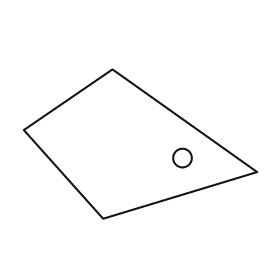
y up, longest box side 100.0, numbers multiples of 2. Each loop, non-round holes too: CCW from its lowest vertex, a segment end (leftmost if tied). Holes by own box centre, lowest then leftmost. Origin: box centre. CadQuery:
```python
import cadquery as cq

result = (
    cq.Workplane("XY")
    .moveTo(-16.0, -32.0)
    .lineTo(50.0, -12.0)
    .lineTo(-12.0, 32.0)
    .lineTo(-50.0, 6.0)
    .close()
    .moveTo(18.0, -6.0)
    .circle(4.0)
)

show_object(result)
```